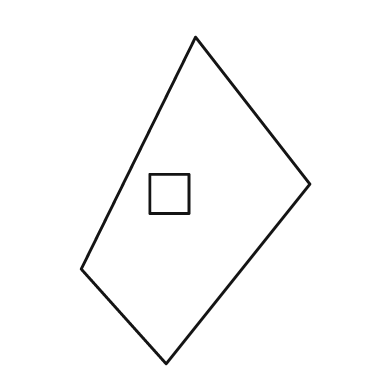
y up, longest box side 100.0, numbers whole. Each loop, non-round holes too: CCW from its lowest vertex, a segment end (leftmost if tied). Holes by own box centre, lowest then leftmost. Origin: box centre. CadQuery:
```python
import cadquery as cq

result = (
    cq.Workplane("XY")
    .moveTo(-9.0, -50.0)
    .lineTo(35.0, 5.0)
    .lineTo(0.0, 50.0)
    .lineTo(-35.0, -21.0)
    .close()
    .moveTo(-14.0, -4.0)
    .lineTo(-2.0, -4.0)
    .lineTo(-2.0, 8.0)
    .lineTo(-14.0, 8.0)
    .close()
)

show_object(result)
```